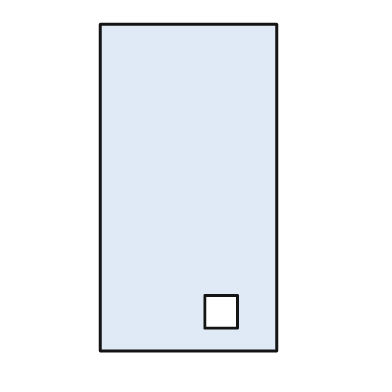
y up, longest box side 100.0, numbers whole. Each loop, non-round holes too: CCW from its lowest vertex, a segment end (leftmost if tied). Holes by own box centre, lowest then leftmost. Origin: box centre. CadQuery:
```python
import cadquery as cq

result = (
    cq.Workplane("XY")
    .moveTo(-27.0, -50.0)
    .lineTo(27.0, -50.0)
    .lineTo(27.0, 50.0)
    .lineTo(-27.0, 50.0)
    .close()
    .moveTo(5.0, -43.0)
    .lineTo(15.0, -43.0)
    .lineTo(15.0, -33.0)
    .lineTo(5.0, -33.0)
    .close()
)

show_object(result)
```